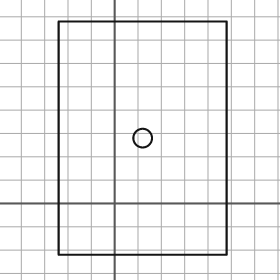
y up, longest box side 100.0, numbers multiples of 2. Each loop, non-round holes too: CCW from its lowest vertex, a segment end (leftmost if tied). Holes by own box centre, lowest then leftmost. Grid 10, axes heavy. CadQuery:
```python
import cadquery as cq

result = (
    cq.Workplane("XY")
    .moveTo(-24.0, -22.0)
    .lineTo(48.0, -22.0)
    .lineTo(48.0, 78.0)
    .lineTo(-24.0, 78.0)
    .close()
    .moveTo(12.0, 28.0)
    .circle(4.0)
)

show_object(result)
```